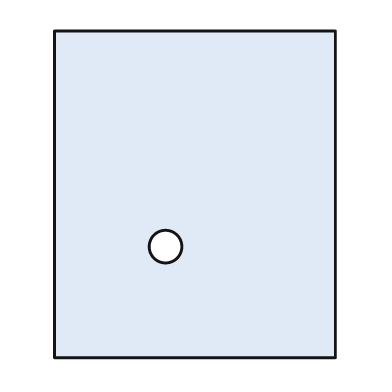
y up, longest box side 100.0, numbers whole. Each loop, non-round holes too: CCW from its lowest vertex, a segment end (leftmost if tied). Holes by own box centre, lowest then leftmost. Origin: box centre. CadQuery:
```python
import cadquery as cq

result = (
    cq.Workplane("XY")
    .moveTo(-43.0, -50.0)
    .lineTo(43.0, -50.0)
    .lineTo(43.0, 50.0)
    .lineTo(-43.0, 50.0)
    .close()
    .moveTo(-9.0, -16.0)
    .circle(5.0)
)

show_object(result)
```